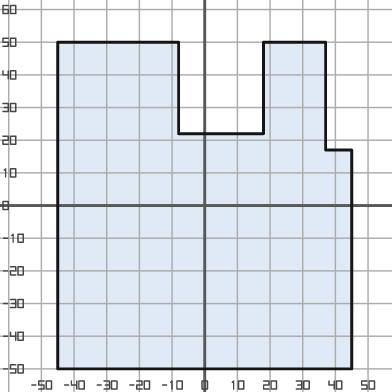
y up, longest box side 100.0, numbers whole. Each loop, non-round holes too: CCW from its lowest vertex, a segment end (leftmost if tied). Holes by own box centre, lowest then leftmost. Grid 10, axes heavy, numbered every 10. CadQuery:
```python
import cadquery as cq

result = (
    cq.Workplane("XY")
    .moveTo(-45.0, -50.0)
    .lineTo(45.0, -50.0)
    .lineTo(45.0, 17.0)
    .lineTo(37.0, 17.0)
    .lineTo(37.0, 50.0)
    .lineTo(18.0, 50.0)
    .lineTo(18.0, 22.0)
    .lineTo(-8.0, 22.0)
    .lineTo(-8.0, 50.0)
    .lineTo(-45.0, 50.0)
    .close()
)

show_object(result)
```